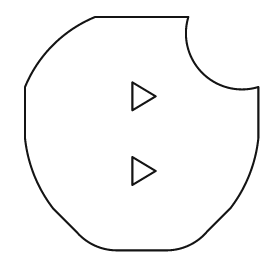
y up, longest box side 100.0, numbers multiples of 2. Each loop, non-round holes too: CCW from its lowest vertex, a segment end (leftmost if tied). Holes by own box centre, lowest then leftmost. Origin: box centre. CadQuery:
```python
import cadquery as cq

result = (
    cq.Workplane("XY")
    .moveTo(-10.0, -50.0)
    .lineTo(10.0, -50.0)
    .threePointArc((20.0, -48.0), (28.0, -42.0))
    .lineTo(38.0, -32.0)
    .threePointArc((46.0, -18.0), (50.0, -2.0))
    .lineTo(50.0, 20.0)
    .threePointArc((26.0, 26.0), (20.0, 50.0))
    .lineTo(-20.0, 50.0)
    .threePointArc((-38.0, 38.0), (-50.0, 20.0))
    .lineTo(-50.0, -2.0)
    .threePointArc((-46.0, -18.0), (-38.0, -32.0))
    .lineTo(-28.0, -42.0)
    .threePointArc((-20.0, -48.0), (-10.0, -50.0))
    .close()
    .moveTo(-4.0, -22.0)
    .lineTo(6.0, -16.0)
    .lineTo(-4.0, -10.0)
    .close()
    .moveTo(-4.0, 10.0)
    .lineTo(6.0, 16.0)
    .lineTo(-4.0, 22.0)
    .close()
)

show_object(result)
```